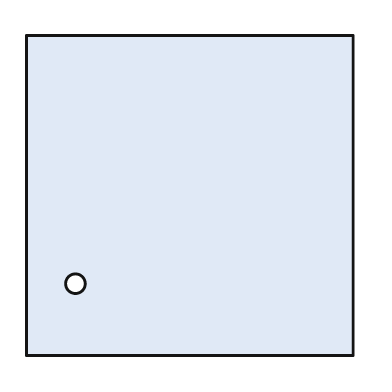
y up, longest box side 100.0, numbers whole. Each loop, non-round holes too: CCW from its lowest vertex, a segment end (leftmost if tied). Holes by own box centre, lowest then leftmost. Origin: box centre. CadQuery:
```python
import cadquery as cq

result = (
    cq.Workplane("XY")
    .moveTo(-50.0, -49.0)
    .lineTo(50.0, -49.0)
    .lineTo(50.0, 49.0)
    .lineTo(-50.0, 49.0)
    .close()
    .moveTo(-35.0, -27.0)
    .circle(3.0)
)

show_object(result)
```